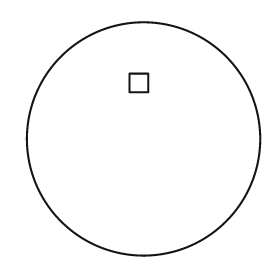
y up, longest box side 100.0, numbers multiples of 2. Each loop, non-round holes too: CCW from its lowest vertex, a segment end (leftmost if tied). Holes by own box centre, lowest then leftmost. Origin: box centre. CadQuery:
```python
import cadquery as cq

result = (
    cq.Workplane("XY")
    .moveTo(0.0, 0.0)
    .circle(50.0)
    .moveTo(-6.0, 20.0)
    .lineTo(2.0, 20.0)
    .lineTo(2.0, 28.0)
    .lineTo(-6.0, 28.0)
    .close()
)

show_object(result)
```